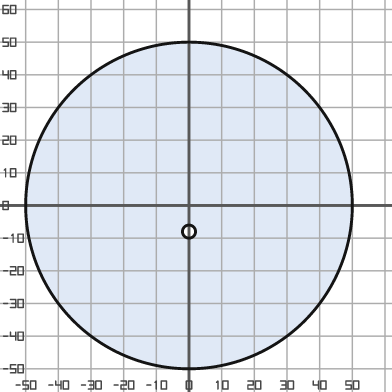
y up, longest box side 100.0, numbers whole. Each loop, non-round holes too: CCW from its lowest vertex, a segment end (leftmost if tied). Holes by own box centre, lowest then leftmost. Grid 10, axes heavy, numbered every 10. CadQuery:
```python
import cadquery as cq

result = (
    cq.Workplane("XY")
    .moveTo(0.0, 0.0)
    .circle(50.0)
    .moveTo(0.0, -8.0)
    .circle(2.0)
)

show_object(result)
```